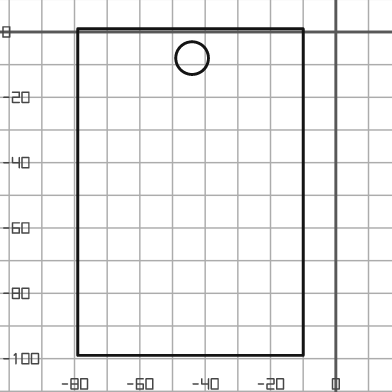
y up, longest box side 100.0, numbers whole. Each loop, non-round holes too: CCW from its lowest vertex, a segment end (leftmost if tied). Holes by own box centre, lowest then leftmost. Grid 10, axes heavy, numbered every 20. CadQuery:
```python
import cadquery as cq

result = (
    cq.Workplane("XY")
    .moveTo(-79.0, -99.0)
    .lineTo(-10.0, -99.0)
    .lineTo(-10.0, 1.0)
    .lineTo(-79.0, 1.0)
    .close()
    .moveTo(-44.0, -8.0)
    .circle(5.0)
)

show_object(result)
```